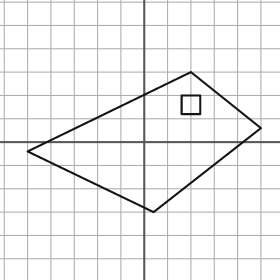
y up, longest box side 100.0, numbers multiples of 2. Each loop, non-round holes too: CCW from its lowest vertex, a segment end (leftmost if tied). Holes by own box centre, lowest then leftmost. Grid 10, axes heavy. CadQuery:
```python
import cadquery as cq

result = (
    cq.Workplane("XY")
    .moveTo(4.0, -30.0)
    .lineTo(50.0, 6.0)
    .lineTo(20.0, 30.0)
    .lineTo(-50.0, -4.0)
    .close()
    .moveTo(16.0, 12.0)
    .lineTo(24.0, 12.0)
    .lineTo(24.0, 20.0)
    .lineTo(16.0, 20.0)
    .close()
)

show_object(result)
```